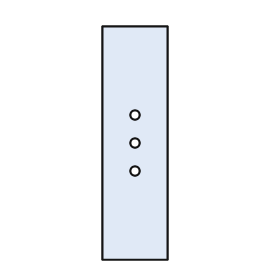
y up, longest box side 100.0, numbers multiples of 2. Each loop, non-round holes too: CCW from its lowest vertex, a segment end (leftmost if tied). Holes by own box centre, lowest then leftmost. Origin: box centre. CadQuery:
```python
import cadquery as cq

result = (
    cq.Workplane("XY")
    .moveTo(-14.0, -50.0)
    .lineTo(14.0, -50.0)
    .lineTo(14.0, 50.0)
    .lineTo(-14.0, 50.0)
    .close()
    .moveTo(0.0, -12.0)
    .circle(2.0)
    .moveTo(0.0, 0.0)
    .circle(2.0)
    .moveTo(0.0, 12.0)
    .circle(2.0)
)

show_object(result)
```